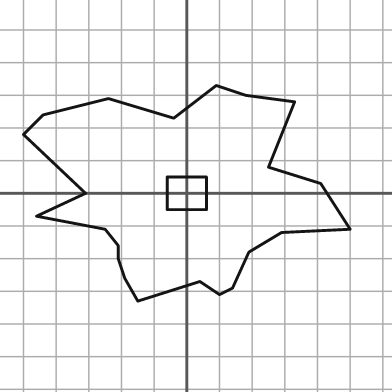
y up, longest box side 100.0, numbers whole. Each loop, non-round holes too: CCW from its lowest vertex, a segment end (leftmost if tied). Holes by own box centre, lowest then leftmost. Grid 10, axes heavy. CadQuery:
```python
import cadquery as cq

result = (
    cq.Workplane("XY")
    .moveTo(-15.0, -33.0)
    .lineTo(4.0, -27.0)
    .lineTo(10.0, -31.0)
    .lineTo(14.0, -29.0)
    .lineTo(19.0, -18.0)
    .lineTo(29.0, -12.0)
    .lineTo(50.0, -11.0)
    .lineTo(41.0, 3.0)
    .lineTo(25.0, 8.0)
    .lineTo(33.0, 28.0)
    .lineTo(18.0, 30.0)
    .lineTo(9.0, 33.0)
    .lineTo(-4.0, 23.0)
    .lineTo(-24.0, 29.0)
    .lineTo(-44.0, 24.0)
    .lineTo(-50.0, 18.0)
    .lineTo(-31.0, 0.0)
    .lineTo(-46.0, -7.0)
    .lineTo(-25.0, -11.0)
    .lineTo(-21.0, -16.0)
    .lineTo(-21.0, -20.0)
    .lineTo(-19.0, -26.0)
    .close()
    .moveTo(-6.0, -5.0)
    .lineTo(6.0, -5.0)
    .lineTo(6.0, 5.0)
    .lineTo(-6.0, 5.0)
    .close()
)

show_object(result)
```